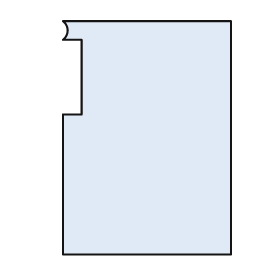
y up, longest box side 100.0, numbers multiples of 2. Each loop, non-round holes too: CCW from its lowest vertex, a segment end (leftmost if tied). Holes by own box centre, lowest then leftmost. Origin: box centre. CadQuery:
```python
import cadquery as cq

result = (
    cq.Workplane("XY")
    .moveTo(-36.0, -50.0)
    .lineTo(36.0, -50.0)
    .lineTo(36.0, 50.0)
    .lineTo(-36.0, 50.0)
    .threePointArc((-34.0, 46.0), (-36.0, 42.0))
    .lineTo(-28.0, 42.0)
    .lineTo(-28.0, 10.0)
    .lineTo(-36.0, 10.0)
    .close()
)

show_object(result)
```